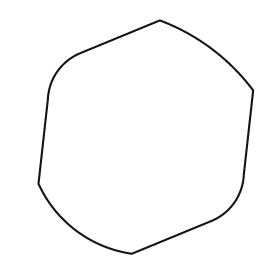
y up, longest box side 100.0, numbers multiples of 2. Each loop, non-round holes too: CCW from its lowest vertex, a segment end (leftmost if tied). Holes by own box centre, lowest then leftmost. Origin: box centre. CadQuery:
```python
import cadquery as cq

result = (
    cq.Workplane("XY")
    .moveTo(-6.0, -50.0)
    .lineTo(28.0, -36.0)
    .threePointArc((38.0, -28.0), (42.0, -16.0))
    .lineTo(46.0, 20.0)
    .threePointArc((28.0, 38.0), (6.0, 50.0))
    .lineTo(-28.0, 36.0)
    .threePointArc((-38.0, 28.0), (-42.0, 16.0))
    .lineTo(-46.0, -20.0)
    .threePointArc((-30.0, -40.0), (-6.0, -50.0))
    .close()
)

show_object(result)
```